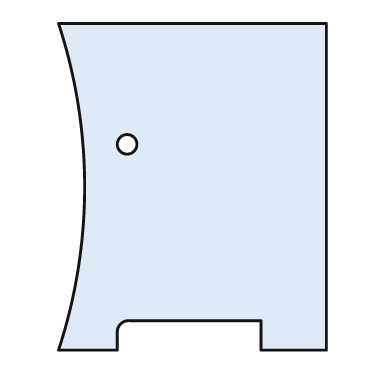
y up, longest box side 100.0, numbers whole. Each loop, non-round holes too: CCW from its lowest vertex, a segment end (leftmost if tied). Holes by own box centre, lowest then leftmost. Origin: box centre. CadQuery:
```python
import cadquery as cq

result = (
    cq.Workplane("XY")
    .moveTo(-41.0, -50.0)
    .lineTo(-23.0, -50.0)
    .lineTo(-23.0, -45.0)
    .threePointArc((-22.0, -42.0), (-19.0, -41.0))
    .lineTo(21.0, -41.0)
    .lineTo(21.0, -50.0)
    .lineTo(41.0, -50.0)
    .lineTo(41.0, 50.0)
    .lineTo(-41.0, 50.0)
    .threePointArc((-33.0, 0.0), (-41.0, -50.0))
    .close()
    .moveTo(-20.0, 13.0)
    .circle(3.0)
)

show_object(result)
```